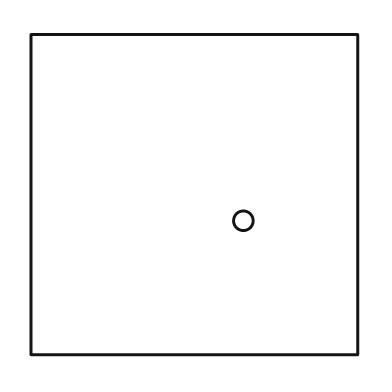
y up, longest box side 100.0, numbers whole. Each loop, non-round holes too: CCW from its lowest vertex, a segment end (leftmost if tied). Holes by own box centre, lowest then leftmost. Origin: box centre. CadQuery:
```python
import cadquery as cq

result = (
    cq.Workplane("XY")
    .moveTo(-50.0, -49.0)
    .lineTo(50.0, -49.0)
    .lineTo(50.0, 49.0)
    .lineTo(-50.0, 49.0)
    .close()
    .moveTo(15.0, -8.0)
    .circle(3.0)
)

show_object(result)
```